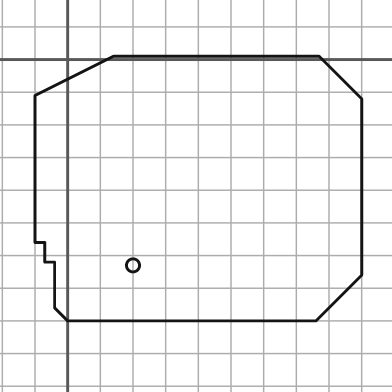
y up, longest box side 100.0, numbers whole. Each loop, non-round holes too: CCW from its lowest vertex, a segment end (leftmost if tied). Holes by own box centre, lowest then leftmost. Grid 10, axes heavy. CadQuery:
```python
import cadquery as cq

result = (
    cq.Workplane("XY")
    .moveTo(0.0, -80.0)
    .lineTo(76.0, -80.0)
    .lineTo(90.0, -66.0)
    .lineTo(90.0, -12.0)
    .lineTo(77.0, 1.0)
    .lineTo(14.0, 1.0)
    .lineTo(-10.0, -11.0)
    .lineTo(-10.0, -56.0)
    .lineTo(-7.0, -56.0)
    .lineTo(-7.0, -62.0)
    .lineTo(-4.0, -62.0)
    .lineTo(-4.0, -76.0)
    .close()
    .moveTo(20.0, -63.0)
    .circle(2.0)
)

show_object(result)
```